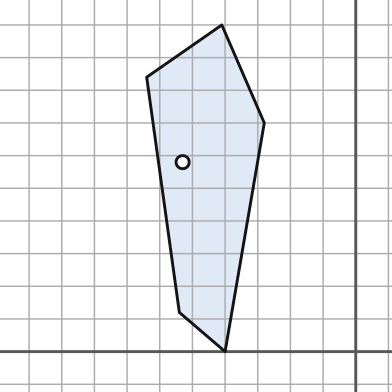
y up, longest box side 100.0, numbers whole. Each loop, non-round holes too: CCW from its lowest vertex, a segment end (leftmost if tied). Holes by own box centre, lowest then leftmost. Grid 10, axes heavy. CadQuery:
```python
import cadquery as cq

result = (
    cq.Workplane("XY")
    .moveTo(-40.0, 0.0)
    .lineTo(-28.0, 70.0)
    .lineTo(-41.0, 100.0)
    .lineTo(-64.0, 84.0)
    .lineTo(-54.0, 12.0)
    .close()
    .moveTo(-53.0, 58.0)
    .circle(2.0)
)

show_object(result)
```